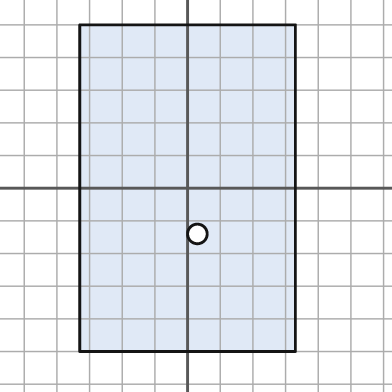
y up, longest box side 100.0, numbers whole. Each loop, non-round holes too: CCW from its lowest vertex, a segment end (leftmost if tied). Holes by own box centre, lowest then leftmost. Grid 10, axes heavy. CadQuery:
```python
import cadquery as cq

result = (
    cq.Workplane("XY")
    .moveTo(-33.0, -50.0)
    .lineTo(33.0, -50.0)
    .lineTo(33.0, 50.0)
    .lineTo(-33.0, 50.0)
    .close()
    .moveTo(3.0, -14.0)
    .circle(3.0)
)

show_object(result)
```